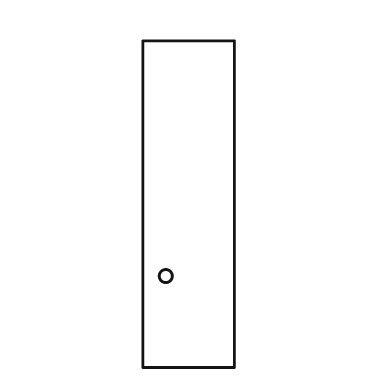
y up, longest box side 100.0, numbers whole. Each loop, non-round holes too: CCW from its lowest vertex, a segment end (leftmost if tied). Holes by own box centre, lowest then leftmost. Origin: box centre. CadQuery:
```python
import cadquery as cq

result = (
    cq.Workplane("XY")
    .moveTo(-14.0, -50.0)
    .lineTo(14.0, -50.0)
    .lineTo(14.0, 50.0)
    .lineTo(-14.0, 50.0)
    .close()
    .moveTo(-7.0, -22.0)
    .circle(2.0)
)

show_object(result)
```